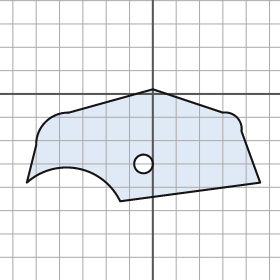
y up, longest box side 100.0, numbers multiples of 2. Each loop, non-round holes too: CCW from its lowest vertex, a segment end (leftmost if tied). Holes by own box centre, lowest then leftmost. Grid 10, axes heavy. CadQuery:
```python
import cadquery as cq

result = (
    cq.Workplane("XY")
    .moveTo(-14.0, -46.0)
    .lineTo(46.0, -38.0)
    .lineTo(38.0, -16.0)
    .threePointArc((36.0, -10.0), (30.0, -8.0))
    .lineTo(0.0, 2.0)
    .lineTo(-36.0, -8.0)
    .threePointArc((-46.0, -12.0), (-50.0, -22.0))
    .lineTo(-54.0, -38.0)
    .threePointArc((-32.0, -32.0), (-14.0, -46.0))
    .close()
    .moveTo(-4.0, -30.0)
    .circle(4.0)
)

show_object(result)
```